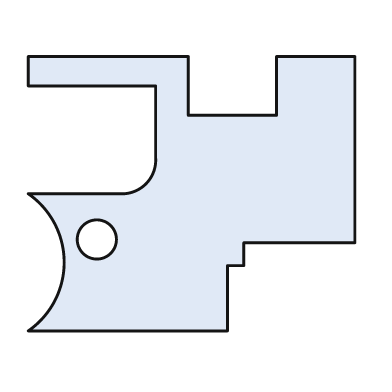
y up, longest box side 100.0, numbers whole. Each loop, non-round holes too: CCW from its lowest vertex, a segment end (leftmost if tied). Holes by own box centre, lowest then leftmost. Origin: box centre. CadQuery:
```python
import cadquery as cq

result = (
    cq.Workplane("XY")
    .moveTo(-50.0, -42.0)
    .lineTo(11.0, -42.0)
    .lineTo(11.0, -22.0)
    .lineTo(16.0, -22.0)
    .lineTo(16.0, -15.0)
    .lineTo(50.0, -15.0)
    .lineTo(50.0, 42.0)
    .lineTo(26.0, 42.0)
    .lineTo(26.0, 24.0)
    .lineTo(-1.0, 24.0)
    .lineTo(-1.0, 42.0)
    .lineTo(-50.0, 42.0)
    .lineTo(-50.0, 33.0)
    .lineTo(-11.0, 33.0)
    .lineTo(-11.0, 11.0)
    .threePointArc((-14.0, 3.0), (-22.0, 0.0))
    .lineTo(-50.0, 0.0)
    .threePointArc((-39.0, -21.0), (-50.0, -42.0))
    .close()
    .moveTo(-29.0, -14.0)
    .circle(6.0)
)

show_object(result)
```